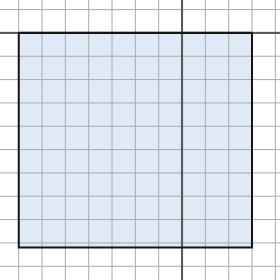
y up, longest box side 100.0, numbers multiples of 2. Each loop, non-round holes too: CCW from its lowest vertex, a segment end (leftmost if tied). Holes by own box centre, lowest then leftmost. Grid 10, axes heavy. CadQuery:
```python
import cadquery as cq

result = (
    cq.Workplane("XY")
    .moveTo(-70.0, -92.0)
    .lineTo(30.0, -92.0)
    .lineTo(30.0, 0.0)
    .lineTo(-70.0, 0.0)
    .close()
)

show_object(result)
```